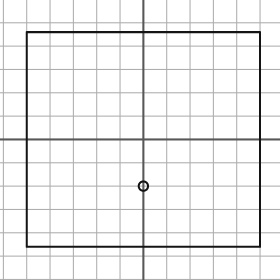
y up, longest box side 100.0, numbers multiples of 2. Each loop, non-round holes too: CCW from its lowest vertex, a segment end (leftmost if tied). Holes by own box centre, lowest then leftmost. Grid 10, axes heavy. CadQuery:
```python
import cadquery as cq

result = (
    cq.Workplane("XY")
    .moveTo(-50.0, -46.0)
    .lineTo(50.0, -46.0)
    .lineTo(50.0, 46.0)
    .lineTo(-50.0, 46.0)
    .close()
    .moveTo(0.0, -20.0)
    .circle(2.0)
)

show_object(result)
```